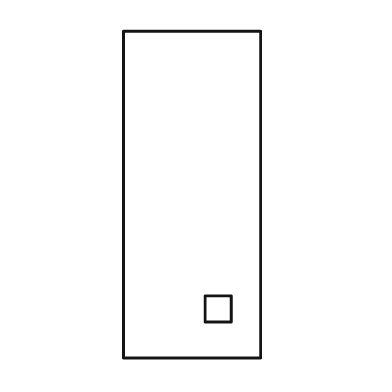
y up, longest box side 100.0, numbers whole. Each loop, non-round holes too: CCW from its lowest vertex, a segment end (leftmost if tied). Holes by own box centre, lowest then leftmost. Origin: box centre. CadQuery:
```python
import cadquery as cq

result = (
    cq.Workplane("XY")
    .moveTo(-21.0, -50.0)
    .lineTo(21.0, -50.0)
    .lineTo(21.0, 50.0)
    .lineTo(-21.0, 50.0)
    .close()
    .moveTo(4.0, -39.0)
    .lineTo(12.0, -39.0)
    .lineTo(12.0, -31.0)
    .lineTo(4.0, -31.0)
    .close()
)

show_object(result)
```